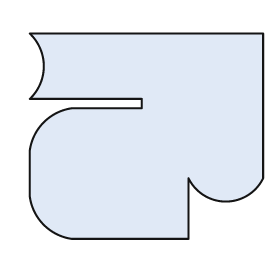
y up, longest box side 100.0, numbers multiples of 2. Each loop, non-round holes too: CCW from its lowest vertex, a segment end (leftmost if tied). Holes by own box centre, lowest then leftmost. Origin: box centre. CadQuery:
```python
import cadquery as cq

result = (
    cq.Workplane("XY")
    .moveTo(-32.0, -44.0)
    .lineTo(18.0, -44.0)
    .lineTo(18.0, -18.0)
    .threePointArc((34.0, -28.0), (50.0, -18.0))
    .lineTo(50.0, 44.0)
    .lineTo(-50.0, 44.0)
    .threePointArc((-44.0, 30.0), (-50.0, 16.0))
    .lineTo(-2.0, 16.0)
    .lineTo(-2.0, 12.0)
    .lineTo(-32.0, 12.0)
    .threePointArc((-44.0, 6.0), (-50.0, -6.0))
    .lineTo(-50.0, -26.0)
    .threePointArc((-44.0, -38.0), (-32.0, -44.0))
    .close()
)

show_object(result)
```